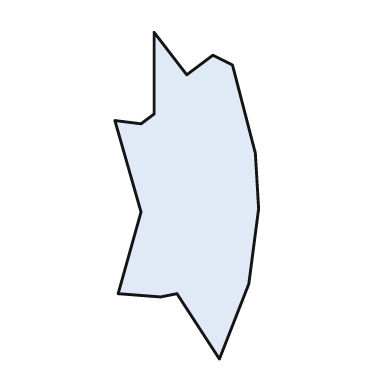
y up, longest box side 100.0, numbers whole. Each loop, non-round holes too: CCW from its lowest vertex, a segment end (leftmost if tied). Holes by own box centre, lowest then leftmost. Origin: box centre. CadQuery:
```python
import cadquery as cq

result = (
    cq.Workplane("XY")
    .moveTo(10.0, -50.0)
    .lineTo(19.0, -27.0)
    .lineTo(22.0, -4.0)
    .lineTo(21.0, 13.0)
    .lineTo(14.0, 40.0)
    .lineTo(8.0, 43.0)
    .lineTo(0.0, 37.0)
    .lineTo(-10.0, 50.0)
    .lineTo(-10.0, 25.0)
    .lineTo(-14.0, 22.0)
    .lineTo(-22.0, 23.0)
    .lineTo(-14.0, -5.0)
    .lineTo(-21.0, -30.0)
    .lineTo(-8.0, -31.0)
    .lineTo(-3.0, -30.0)
    .close()
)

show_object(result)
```